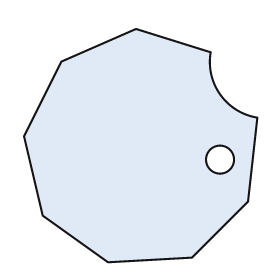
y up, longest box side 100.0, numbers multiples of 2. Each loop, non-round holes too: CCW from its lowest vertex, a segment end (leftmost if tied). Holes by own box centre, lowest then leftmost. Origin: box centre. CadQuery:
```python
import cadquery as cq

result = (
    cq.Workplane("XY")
    .moveTo(-14.0, -50.0)
    .lineTo(22.0, -48.0)
    .lineTo(46.0, -24.0)
    .lineTo(50.0, 12.0)
    .threePointArc((34.0, 22.0), (30.0, 40.0))
    .lineTo(-2.0, 50.0)
    .lineTo(-34.0, 36.0)
    .lineTo(-50.0, 4.0)
    .lineTo(-42.0, -30.0)
    .close()
    .moveTo(34.0, -6.0)
    .circle(6.0)
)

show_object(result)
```